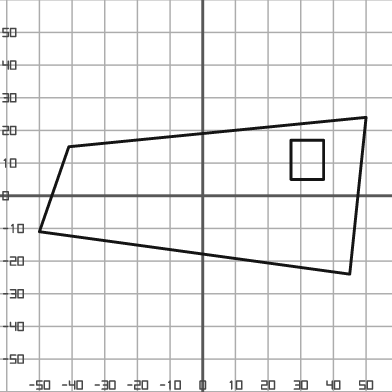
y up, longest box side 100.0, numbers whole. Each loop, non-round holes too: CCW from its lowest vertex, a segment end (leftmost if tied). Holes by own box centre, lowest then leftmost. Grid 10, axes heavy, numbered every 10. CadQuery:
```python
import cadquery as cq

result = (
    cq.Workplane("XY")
    .moveTo(45.0, -24.0)
    .lineTo(50.0, 24.0)
    .lineTo(-41.0, 15.0)
    .lineTo(-50.0, -11.0)
    .close()
    .moveTo(27.0, 5.0)
    .lineTo(37.0, 5.0)
    .lineTo(37.0, 17.0)
    .lineTo(27.0, 17.0)
    .close()
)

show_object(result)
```